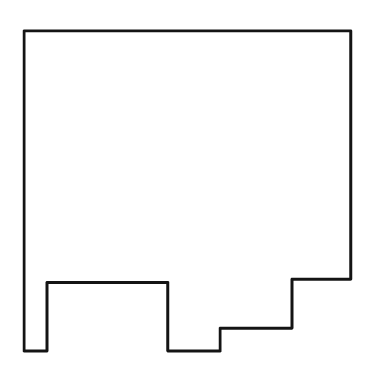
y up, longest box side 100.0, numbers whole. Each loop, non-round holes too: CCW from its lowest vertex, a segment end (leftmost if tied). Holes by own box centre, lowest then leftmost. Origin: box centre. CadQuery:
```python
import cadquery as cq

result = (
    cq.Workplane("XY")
    .moveTo(-50.0, -49.0)
    .lineTo(-43.0, -49.0)
    .lineTo(-43.0, -28.0)
    .lineTo(-6.0, -28.0)
    .lineTo(-6.0, -49.0)
    .lineTo(10.0, -49.0)
    .lineTo(10.0, -42.0)
    .lineTo(32.0, -42.0)
    .lineTo(32.0, -27.0)
    .lineTo(50.0, -27.0)
    .lineTo(50.0, 49.0)
    .lineTo(-50.0, 49.0)
    .close()
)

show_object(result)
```